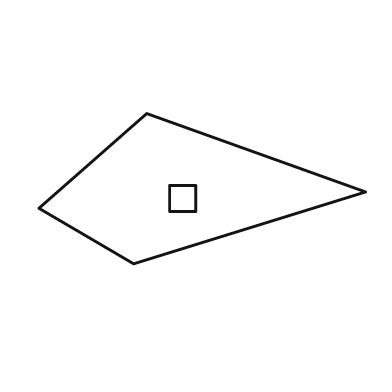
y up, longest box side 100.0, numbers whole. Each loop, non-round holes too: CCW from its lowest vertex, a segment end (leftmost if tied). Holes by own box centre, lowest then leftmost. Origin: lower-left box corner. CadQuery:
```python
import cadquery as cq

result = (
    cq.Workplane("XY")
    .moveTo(29.0, 0.0)
    .lineTo(100.0, 22.0)
    .lineTo(33.0, 46.0)
    .lineTo(0.0, 17.0)
    .close()
    .moveTo(40.0, 16.0)
    .lineTo(48.0, 16.0)
    .lineTo(48.0, 24.0)
    .lineTo(40.0, 24.0)
    .close()
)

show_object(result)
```